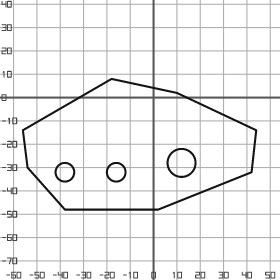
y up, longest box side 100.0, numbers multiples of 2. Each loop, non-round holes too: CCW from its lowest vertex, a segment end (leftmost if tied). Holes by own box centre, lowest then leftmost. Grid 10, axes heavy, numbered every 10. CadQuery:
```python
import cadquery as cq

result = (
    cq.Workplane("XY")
    .moveTo(-38.0, -48.0)
    .lineTo(2.0, -48.0)
    .lineTo(42.0, -32.0)
    .lineTo(44.0, -14.0)
    .lineTo(10.0, 2.0)
    .lineTo(-18.0, 8.0)
    .lineTo(-56.0, -14.0)
    .lineTo(-54.0, -30.0)
    .close()
    .moveTo(-38.0, -32.0)
    .circle(4.0)
    .moveTo(-16.0, -32.0)
    .circle(4.0)
    .moveTo(12.0, -28.0)
    .circle(6.0)
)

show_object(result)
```